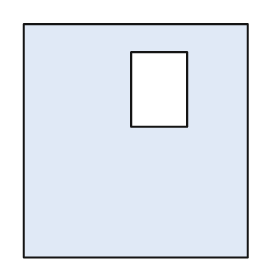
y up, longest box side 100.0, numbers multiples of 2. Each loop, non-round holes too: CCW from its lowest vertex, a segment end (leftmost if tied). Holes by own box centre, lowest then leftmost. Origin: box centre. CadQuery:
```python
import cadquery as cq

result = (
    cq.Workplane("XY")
    .moveTo(-48.0, -50.0)
    .lineTo(48.0, -50.0)
    .lineTo(48.0, 50.0)
    .lineTo(-48.0, 50.0)
    .close()
    .moveTo(-2.0, 6.0)
    .lineTo(22.0, 6.0)
    .lineTo(22.0, 38.0)
    .lineTo(-2.0, 38.0)
    .close()
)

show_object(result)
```